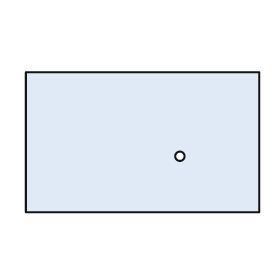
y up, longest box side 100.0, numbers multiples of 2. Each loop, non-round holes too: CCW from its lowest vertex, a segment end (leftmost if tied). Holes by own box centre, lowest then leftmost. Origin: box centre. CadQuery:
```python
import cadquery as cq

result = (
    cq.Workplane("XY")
    .moveTo(-50.0, -30.0)
    .lineTo(50.0, -30.0)
    .lineTo(50.0, 30.0)
    .lineTo(-50.0, 30.0)
    .close()
    .moveTo(16.0, -6.0)
    .circle(2.0)
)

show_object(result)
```